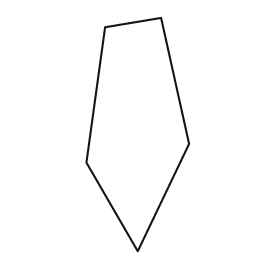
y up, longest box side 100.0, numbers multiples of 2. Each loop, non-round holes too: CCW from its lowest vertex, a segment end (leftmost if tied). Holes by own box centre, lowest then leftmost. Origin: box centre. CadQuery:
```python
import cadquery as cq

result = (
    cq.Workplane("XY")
    .moveTo(0.0, -50.0)
    .lineTo(22.0, -4.0)
    .lineTo(10.0, 50.0)
    .lineTo(-14.0, 46.0)
    .lineTo(-22.0, -12.0)
    .close()
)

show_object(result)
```